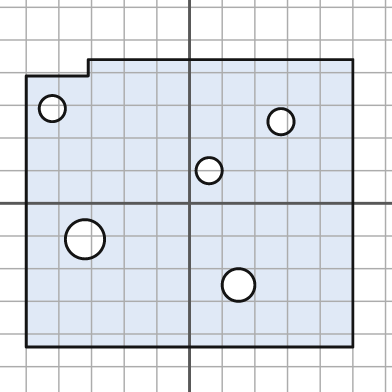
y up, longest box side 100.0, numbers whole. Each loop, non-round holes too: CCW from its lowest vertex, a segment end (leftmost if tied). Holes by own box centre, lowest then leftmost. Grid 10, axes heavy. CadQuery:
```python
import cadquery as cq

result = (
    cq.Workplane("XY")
    .moveTo(-50.0, -44.0)
    .lineTo(50.0, -44.0)
    .lineTo(50.0, 44.0)
    .lineTo(-31.0, 44.0)
    .lineTo(-31.0, 39.0)
    .lineTo(-50.0, 39.0)
    .close()
    .moveTo(15.0, -25.0)
    .circle(5.0)
    .moveTo(-32.0, -11.0)
    .circle(6.0)
    .moveTo(6.0, 10.0)
    .circle(4.0)
    .moveTo(28.0, 25.0)
    .circle(4.0)
    .moveTo(-42.0, 29.0)
    .circle(4.0)
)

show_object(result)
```